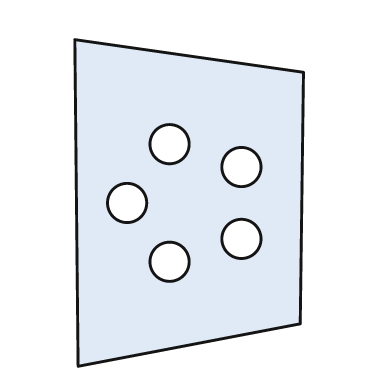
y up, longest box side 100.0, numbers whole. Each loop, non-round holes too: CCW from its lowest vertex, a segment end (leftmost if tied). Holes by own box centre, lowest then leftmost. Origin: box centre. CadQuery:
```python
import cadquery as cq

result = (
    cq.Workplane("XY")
    .moveTo(-34.0, -50.0)
    .lineTo(34.0, -37.0)
    .lineTo(35.0, 40.0)
    .lineTo(-35.0, 50.0)
    .close()
    .moveTo(-6.0, -18.0)
    .circle(6.0)
    .moveTo(16.0, -11.0)
    .circle(6.0)
    .moveTo(-19.0, 0.0)
    .circle(6.0)
    .moveTo(16.0, 11.0)
    .circle(6.0)
    .moveTo(-6.0, 18.0)
    .circle(6.0)
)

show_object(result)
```